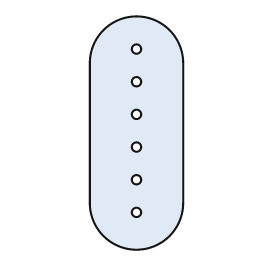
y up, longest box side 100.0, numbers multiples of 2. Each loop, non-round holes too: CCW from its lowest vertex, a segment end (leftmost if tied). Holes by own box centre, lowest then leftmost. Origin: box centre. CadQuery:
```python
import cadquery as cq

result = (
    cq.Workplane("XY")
    .moveTo(-20.0, -30.0)
    .threePointArc((0.0, -50.0), (20.0, -30.0))
    .lineTo(20.0, 30.0)
    .threePointArc((0.0, 50.0), (-20.0, 30.0))
    .close()
    .moveTo(0.0, -34.0)
    .circle(2.0)
    .moveTo(0.0, -20.0)
    .circle(2.0)
    .moveTo(0.0, -6.0)
    .circle(2.0)
    .moveTo(0.0, 8.0)
    .circle(2.0)
    .moveTo(0.0, 22.0)
    .circle(2.0)
    .moveTo(0.0, 36.0)
    .circle(2.0)
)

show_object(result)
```